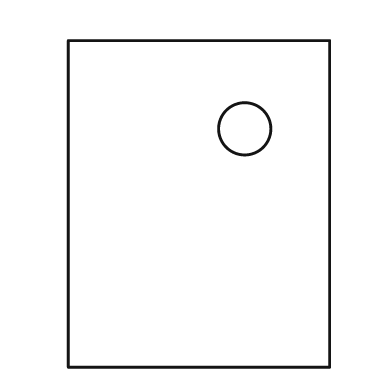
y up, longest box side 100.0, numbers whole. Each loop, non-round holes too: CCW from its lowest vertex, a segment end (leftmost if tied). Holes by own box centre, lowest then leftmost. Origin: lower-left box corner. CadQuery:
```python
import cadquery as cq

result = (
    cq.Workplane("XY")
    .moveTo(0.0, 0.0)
    .lineTo(80.0, 0.0)
    .lineTo(80.0, 100.0)
    .lineTo(0.0, 100.0)
    .close()
    .moveTo(54.0, 73.0)
    .circle(8.0)
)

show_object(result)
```